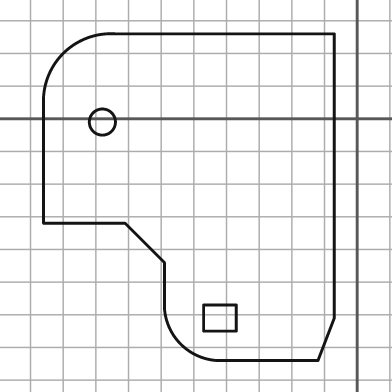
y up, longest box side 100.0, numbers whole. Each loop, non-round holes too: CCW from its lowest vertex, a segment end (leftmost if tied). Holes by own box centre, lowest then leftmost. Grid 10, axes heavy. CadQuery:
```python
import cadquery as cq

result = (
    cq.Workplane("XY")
    .moveTo(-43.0, -74.0)
    .lineTo(-12.0, -74.0)
    .lineTo(-7.0, -61.0)
    .lineTo(-7.0, 26.0)
    .lineTo(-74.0, 26.0)
    .threePointArc((-90.0, 20.0), (-96.0, 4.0))
    .lineTo(-96.0, -32.0)
    .lineTo(-71.0, -32.0)
    .lineTo(-59.0, -44.0)
    .lineTo(-59.0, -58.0)
    .threePointArc((-54.0, -69.0), (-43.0, -74.0))
    .close()
    .moveTo(-47.0, -65.0)
    .lineTo(-37.0, -65.0)
    .lineTo(-37.0, -57.0)
    .lineTo(-47.0, -57.0)
    .close()
    .moveTo(-78.0, -1.0)
    .circle(4.0)
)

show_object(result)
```